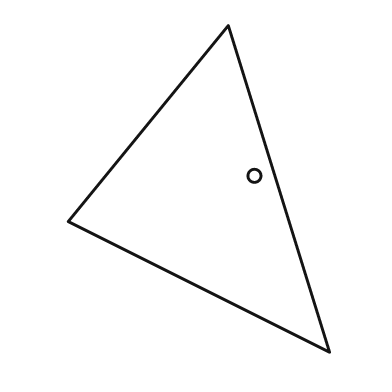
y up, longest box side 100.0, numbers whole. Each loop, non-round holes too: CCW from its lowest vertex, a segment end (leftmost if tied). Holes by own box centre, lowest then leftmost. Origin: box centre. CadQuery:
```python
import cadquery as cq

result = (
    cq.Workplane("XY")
    .moveTo(40.0, -50.0)
    .lineTo(9.0, 50.0)
    .lineTo(-40.0, -10.0)
    .close()
    .moveTo(17.0, 4.0)
    .circle(2.0)
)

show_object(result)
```